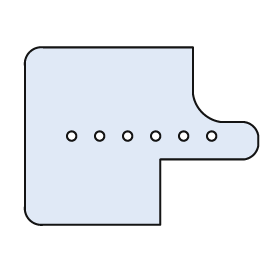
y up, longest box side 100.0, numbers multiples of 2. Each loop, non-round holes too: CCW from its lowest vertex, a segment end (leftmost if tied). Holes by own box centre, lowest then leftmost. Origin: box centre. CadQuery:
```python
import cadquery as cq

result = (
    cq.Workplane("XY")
    .moveTo(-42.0, -38.0)
    .lineTo(8.0, -38.0)
    .lineTo(8.0, -10.0)
    .lineTo(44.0, -10.0)
    .threePointArc((48.0, -8.0), (50.0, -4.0))
    .lineTo(50.0, 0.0)
    .threePointArc((48.0, 4.0), (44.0, 6.0))
    .lineTo(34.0, 6.0)
    .threePointArc((26.0, 10.0), (22.0, 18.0))
    .lineTo(22.0, 38.0)
    .lineTo(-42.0, 38.0)
    .threePointArc((-48.0, 36.0), (-50.0, 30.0))
    .lineTo(-50.0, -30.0)
    .threePointArc((-48.0, -36.0), (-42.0, -38.0))
    .close()
    .moveTo(-30.0, 0.0)
    .circle(2.0)
    .moveTo(-18.0, 0.0)
    .circle(2.0)
    .moveTo(-6.0, 0.0)
    .circle(2.0)
    .moveTo(6.0, 0.0)
    .circle(2.0)
    .moveTo(18.0, 0.0)
    .circle(2.0)
    .moveTo(30.0, 0.0)
    .circle(2.0)
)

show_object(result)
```